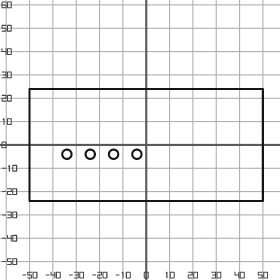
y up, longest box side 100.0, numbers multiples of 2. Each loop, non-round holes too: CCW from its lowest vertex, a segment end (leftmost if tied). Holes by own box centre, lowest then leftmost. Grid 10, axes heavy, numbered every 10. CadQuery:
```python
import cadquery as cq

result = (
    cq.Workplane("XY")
    .moveTo(-50.0, -24.0)
    .lineTo(50.0, -24.0)
    .lineTo(50.0, 24.0)
    .lineTo(-50.0, 24.0)
    .close()
    .moveTo(-34.0, -4.0)
    .circle(2.0)
    .moveTo(-24.0, -4.0)
    .circle(2.0)
    .moveTo(-14.0, -4.0)
    .circle(2.0)
    .moveTo(-4.0, -4.0)
    .circle(2.0)
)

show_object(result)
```